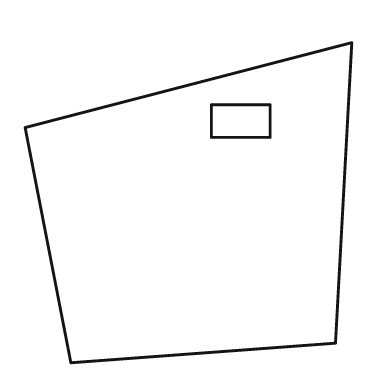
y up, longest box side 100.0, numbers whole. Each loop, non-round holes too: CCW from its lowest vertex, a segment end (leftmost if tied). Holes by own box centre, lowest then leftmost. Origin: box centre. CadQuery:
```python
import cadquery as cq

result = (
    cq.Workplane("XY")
    .moveTo(-36.0, -49.0)
    .lineTo(45.0, -43.0)
    .lineTo(50.0, 49.0)
    .lineTo(-50.0, 23.0)
    .close()
    .moveTo(7.0, 20.0)
    .lineTo(25.0, 20.0)
    .lineTo(25.0, 30.0)
    .lineTo(7.0, 30.0)
    .close()
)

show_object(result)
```